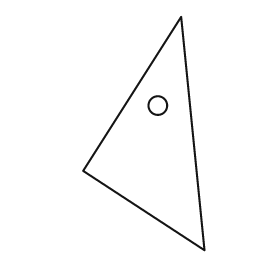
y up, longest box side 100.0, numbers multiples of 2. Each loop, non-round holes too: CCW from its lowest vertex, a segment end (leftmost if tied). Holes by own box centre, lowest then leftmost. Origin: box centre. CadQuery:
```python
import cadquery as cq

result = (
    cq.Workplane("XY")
    .moveTo(26.0, -50.0)
    .lineTo(16.0, 50.0)
    .lineTo(-26.0, -16.0)
    .close()
    .moveTo(6.0, 12.0)
    .circle(4.0)
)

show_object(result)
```